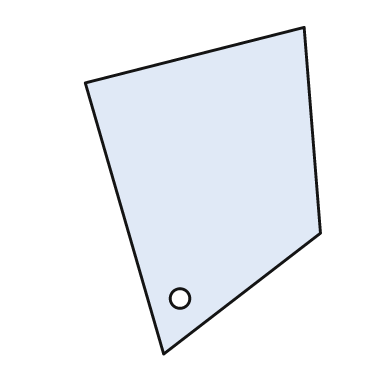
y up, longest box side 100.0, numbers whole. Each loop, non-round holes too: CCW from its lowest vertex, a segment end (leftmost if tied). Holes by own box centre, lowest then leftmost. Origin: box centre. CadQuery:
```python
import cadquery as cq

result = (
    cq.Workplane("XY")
    .moveTo(-12.0, -50.0)
    .lineTo(36.0, -13.0)
    .lineTo(31.0, 50.0)
    .lineTo(-36.0, 33.0)
    .close()
    .moveTo(-7.0, -33.0)
    .circle(3.0)
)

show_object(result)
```